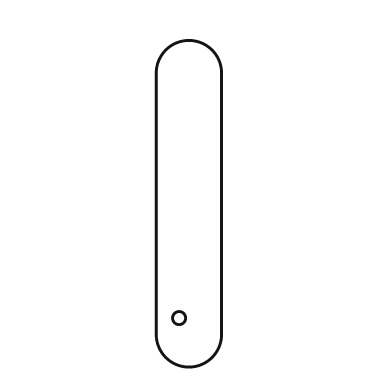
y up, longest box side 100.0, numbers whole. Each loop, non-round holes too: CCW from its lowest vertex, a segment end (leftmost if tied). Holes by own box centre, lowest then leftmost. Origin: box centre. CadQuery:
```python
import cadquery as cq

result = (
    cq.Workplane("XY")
    .moveTo(-10.0, -40.0)
    .threePointArc((0.0, -50.0), (10.0, -40.0))
    .lineTo(10.0, 40.0)
    .threePointArc((0.0, 50.0), (-10.0, 40.0))
    .close()
    .moveTo(-3.0, -35.0)
    .circle(2.0)
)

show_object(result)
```